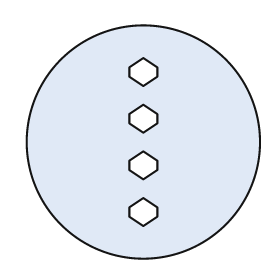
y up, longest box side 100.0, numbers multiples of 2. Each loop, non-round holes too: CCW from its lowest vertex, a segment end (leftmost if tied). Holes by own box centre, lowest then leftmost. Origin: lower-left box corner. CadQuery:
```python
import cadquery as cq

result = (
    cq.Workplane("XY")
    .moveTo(50.0, 50.0)
    .circle(50.0)
    .moveTo(50.0, 14.0)
    .lineTo(56.0, 18.0)
    .lineTo(56.0, 22.0)
    .lineTo(50.0, 26.0)
    .lineTo(44.0, 22.0)
    .lineTo(44.0, 18.0)
    .close()
    .moveTo(50.0, 34.0)
    .lineTo(56.0, 38.0)
    .lineTo(56.0, 42.0)
    .lineTo(50.0, 46.0)
    .lineTo(44.0, 42.0)
    .lineTo(44.0, 38.0)
    .close()
    .moveTo(50.0, 54.0)
    .lineTo(56.0, 58.0)
    .lineTo(56.0, 62.0)
    .lineTo(50.0, 66.0)
    .lineTo(44.0, 62.0)
    .lineTo(44.0, 58.0)
    .close()
    .moveTo(50.0, 74.0)
    .lineTo(56.0, 78.0)
    .lineTo(56.0, 82.0)
    .lineTo(50.0, 86.0)
    .lineTo(44.0, 82.0)
    .lineTo(44.0, 78.0)
    .close()
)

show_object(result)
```